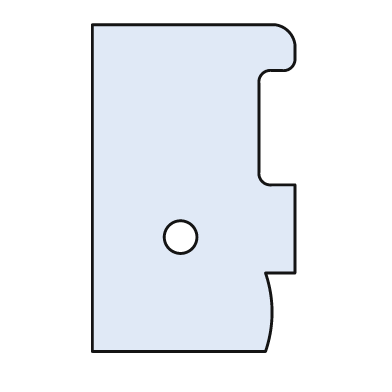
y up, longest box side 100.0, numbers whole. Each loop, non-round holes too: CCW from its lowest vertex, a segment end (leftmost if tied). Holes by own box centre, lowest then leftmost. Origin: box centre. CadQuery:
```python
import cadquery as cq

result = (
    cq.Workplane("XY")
    .moveTo(-31.0, -50.0)
    .lineTo(22.0, -50.0)
    .threePointArc((24.0, -38.0), (22.0, -26.0))
    .lineTo(31.0, -26.0)
    .lineTo(31.0, 1.0)
    .lineTo(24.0, 1.0)
    .threePointArc((21.0, 2.0), (20.0, 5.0))
    .lineTo(20.0, 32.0)
    .threePointArc((21.0, 35.0), (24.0, 36.0))
    .lineTo(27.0, 36.0)
    .threePointArc((30.0, 37.0), (31.0, 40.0))
    .lineTo(31.0, 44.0)
    .threePointArc((29.0, 48.0), (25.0, 50.0))
    .lineTo(-31.0, 50.0)
    .close()
    .moveTo(-4.0, -15.0)
    .circle(5.0)
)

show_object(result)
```